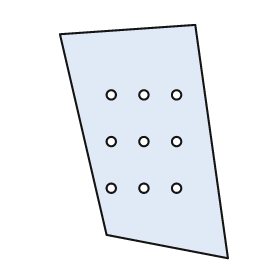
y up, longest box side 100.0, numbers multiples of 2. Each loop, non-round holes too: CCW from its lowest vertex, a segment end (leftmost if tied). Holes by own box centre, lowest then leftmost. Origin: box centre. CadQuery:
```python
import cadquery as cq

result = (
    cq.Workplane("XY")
    .moveTo(36.0, -50.0)
    .lineTo(22.0, 50.0)
    .lineTo(-36.0, 46.0)
    .lineTo(-16.0, -40.0)
    .close()
    .moveTo(-14.0, -20.0)
    .circle(2.0)
    .moveTo(0.0, -20.0)
    .circle(2.0)
    .moveTo(14.0, -20.0)
    .circle(2.0)
    .moveTo(-14.0, 0.0)
    .circle(2.0)
    .moveTo(0.0, 0.0)
    .circle(2.0)
    .moveTo(14.0, 0.0)
    .circle(2.0)
    .moveTo(-14.0, 20.0)
    .circle(2.0)
    .moveTo(0.0, 20.0)
    .circle(2.0)
    .moveTo(14.0, 20.0)
    .circle(2.0)
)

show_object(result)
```